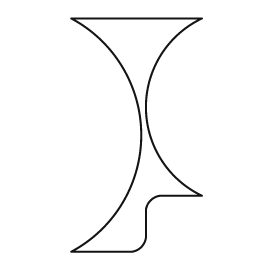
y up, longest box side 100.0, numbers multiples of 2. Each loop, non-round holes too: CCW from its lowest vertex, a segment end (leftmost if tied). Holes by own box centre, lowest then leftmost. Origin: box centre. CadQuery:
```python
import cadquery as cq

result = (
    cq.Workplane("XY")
    .moveTo(-28.0, -50.0)
    .lineTo(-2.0, -50.0)
    .threePointArc((2.0, -48.0), (4.0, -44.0))
    .lineTo(4.0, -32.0)
    .threePointArc((6.0, -28.0), (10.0, -26.0))
    .lineTo(28.0, -26.0)
    .threePointArc((4.0, 12.0), (28.0, 50.0))
    .lineTo(-28.0, 50.0)
    .threePointArc((2.0, 0.0), (-28.0, -50.0))
    .close()
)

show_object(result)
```